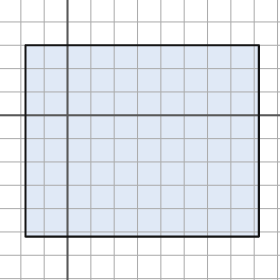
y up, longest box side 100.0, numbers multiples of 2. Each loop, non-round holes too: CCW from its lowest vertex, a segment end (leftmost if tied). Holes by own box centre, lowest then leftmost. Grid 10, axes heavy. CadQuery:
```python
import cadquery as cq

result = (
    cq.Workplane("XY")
    .moveTo(-18.0, -52.0)
    .lineTo(82.0, -52.0)
    .lineTo(82.0, 30.0)
    .lineTo(-18.0, 30.0)
    .close()
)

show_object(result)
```